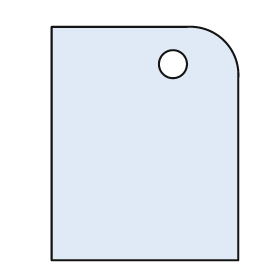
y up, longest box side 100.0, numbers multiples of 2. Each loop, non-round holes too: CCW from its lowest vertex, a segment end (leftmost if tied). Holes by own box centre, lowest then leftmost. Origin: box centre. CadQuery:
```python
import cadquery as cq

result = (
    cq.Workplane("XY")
    .moveTo(-40.0, -50.0)
    .lineTo(40.0, -50.0)
    .lineTo(40.0, 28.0)
    .threePointArc((34.0, 44.0), (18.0, 50.0))
    .lineTo(-40.0, 50.0)
    .close()
    .moveTo(12.0, 34.0)
    .circle(6.0)
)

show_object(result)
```